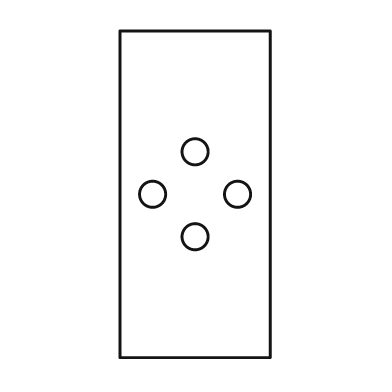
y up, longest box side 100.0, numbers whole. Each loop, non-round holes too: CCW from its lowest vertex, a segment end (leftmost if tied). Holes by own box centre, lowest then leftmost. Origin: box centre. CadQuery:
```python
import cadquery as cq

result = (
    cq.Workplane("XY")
    .moveTo(-23.0, -50.0)
    .lineTo(23.0, -50.0)
    .lineTo(23.0, 50.0)
    .lineTo(-23.0, 50.0)
    .close()
    .moveTo(0.0, -13.0)
    .circle(4.0)
    .moveTo(-13.0, 0.0)
    .circle(4.0)
    .moveTo(13.0, 0.0)
    .circle(4.0)
    .moveTo(0.0, 13.0)
    .circle(4.0)
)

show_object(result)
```